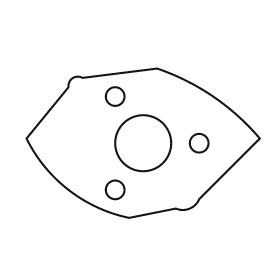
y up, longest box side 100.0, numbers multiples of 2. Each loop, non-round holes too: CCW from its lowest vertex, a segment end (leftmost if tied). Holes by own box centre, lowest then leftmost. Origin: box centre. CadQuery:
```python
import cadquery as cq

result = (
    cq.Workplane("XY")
    .moveTo(-6.0, -32.0)
    .lineTo(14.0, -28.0)
    .threePointArc((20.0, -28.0), (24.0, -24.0))
    .lineTo(50.0, 2.0)
    .threePointArc((30.0, 20.0), (6.0, 32.0))
    .lineTo(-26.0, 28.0)
    .threePointArc((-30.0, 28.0), (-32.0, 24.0))
    .lineTo(-50.0, 2.0)
    .threePointArc((-32.0, -20.0), (-6.0, -32.0))
    .close()
    .moveTo(-12.0, -20.0)
    .circle(4.0)
    .moveTo(0.0, 0.0)
    .circle(12.0)
    .moveTo(24.0, 0.0)
    .circle(4.0)
    .moveTo(-12.0, 20.0)
    .circle(4.0)
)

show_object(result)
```